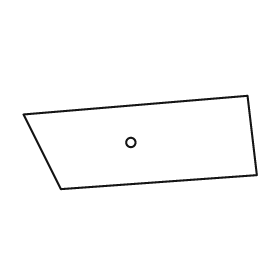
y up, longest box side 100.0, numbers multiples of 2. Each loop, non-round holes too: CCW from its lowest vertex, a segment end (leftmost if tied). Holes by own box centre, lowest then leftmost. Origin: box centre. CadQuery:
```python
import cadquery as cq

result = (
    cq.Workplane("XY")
    .moveTo(-34.0, -20.0)
    .lineTo(50.0, -14.0)
    .lineTo(46.0, 20.0)
    .lineTo(-50.0, 12.0)
    .close()
    .moveTo(-4.0, 0.0)
    .circle(2.0)
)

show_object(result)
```